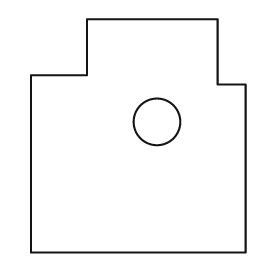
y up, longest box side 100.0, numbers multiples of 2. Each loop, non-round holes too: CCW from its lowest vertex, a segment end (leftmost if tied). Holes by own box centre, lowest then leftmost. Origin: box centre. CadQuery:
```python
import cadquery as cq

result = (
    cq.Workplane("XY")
    .moveTo(-46.0, -50.0)
    .lineTo(46.0, -50.0)
    .lineTo(46.0, 22.0)
    .lineTo(34.0, 22.0)
    .lineTo(34.0, 50.0)
    .lineTo(-22.0, 50.0)
    .lineTo(-22.0, 26.0)
    .lineTo(-46.0, 26.0)
    .close()
    .moveTo(8.0, 6.0)
    .circle(10.0)
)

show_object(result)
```